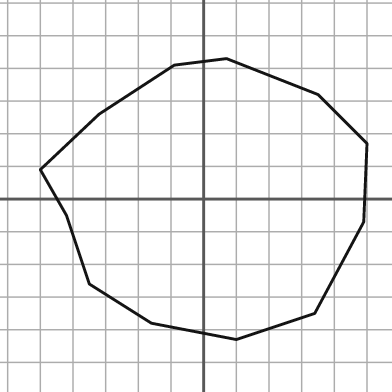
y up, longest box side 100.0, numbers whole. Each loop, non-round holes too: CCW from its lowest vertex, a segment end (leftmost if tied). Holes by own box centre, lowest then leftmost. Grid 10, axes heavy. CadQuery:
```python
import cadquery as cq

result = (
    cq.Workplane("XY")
    .moveTo(10.0, -43.0)
    .lineTo(34.0, -35.0)
    .lineTo(49.0, -7.0)
    .lineTo(50.0, 17.0)
    .lineTo(35.0, 32.0)
    .lineTo(7.0, 43.0)
    .lineTo(-9.0, 41.0)
    .lineTo(-32.0, 26.0)
    .lineTo(-50.0, 9.0)
    .lineTo(-42.0, -5.0)
    .lineTo(-35.0, -26.0)
    .lineTo(-16.0, -38.0)
    .close()
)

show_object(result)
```